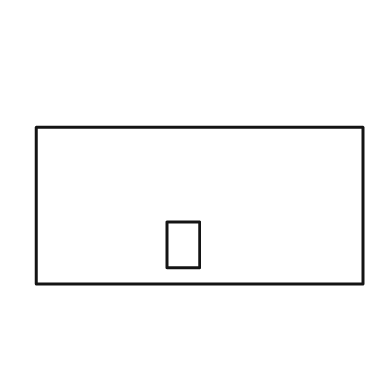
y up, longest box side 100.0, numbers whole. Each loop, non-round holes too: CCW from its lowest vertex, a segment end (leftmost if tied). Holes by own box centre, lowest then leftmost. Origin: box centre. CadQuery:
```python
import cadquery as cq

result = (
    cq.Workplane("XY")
    .moveTo(-50.0, -24.0)
    .lineTo(50.0, -24.0)
    .lineTo(50.0, 24.0)
    .lineTo(-50.0, 24.0)
    .close()
    .moveTo(-10.0, -19.0)
    .lineTo(0.0, -19.0)
    .lineTo(0.0, -5.0)
    .lineTo(-10.0, -5.0)
    .close()
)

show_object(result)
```